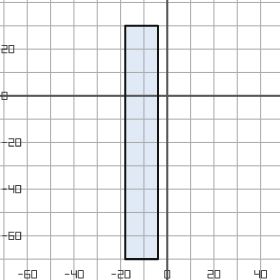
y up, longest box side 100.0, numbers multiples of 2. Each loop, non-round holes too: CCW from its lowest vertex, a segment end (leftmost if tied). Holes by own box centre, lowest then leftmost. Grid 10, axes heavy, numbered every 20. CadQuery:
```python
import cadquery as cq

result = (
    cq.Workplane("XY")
    .moveTo(-18.0, -70.0)
    .lineTo(-4.0, -70.0)
    .lineTo(-4.0, 30.0)
    .lineTo(-18.0, 30.0)
    .close()
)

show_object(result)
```